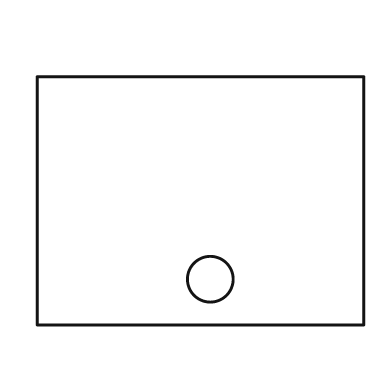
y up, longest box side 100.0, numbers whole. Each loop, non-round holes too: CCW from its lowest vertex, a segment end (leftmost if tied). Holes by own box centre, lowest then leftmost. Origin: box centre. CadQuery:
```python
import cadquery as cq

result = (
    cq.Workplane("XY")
    .moveTo(-50.0, -38.0)
    .lineTo(50.0, -38.0)
    .lineTo(50.0, 38.0)
    .lineTo(-50.0, 38.0)
    .close()
    .moveTo(3.0, -24.0)
    .circle(7.0)
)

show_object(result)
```